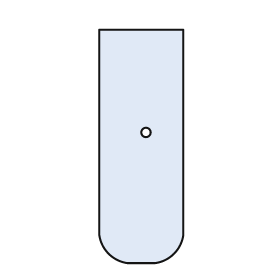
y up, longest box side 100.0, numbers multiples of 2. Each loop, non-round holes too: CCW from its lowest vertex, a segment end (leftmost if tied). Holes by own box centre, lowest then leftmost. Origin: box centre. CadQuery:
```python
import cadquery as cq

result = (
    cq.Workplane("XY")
    .moveTo(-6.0, -50.0)
    .lineTo(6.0, -50.0)
    .threePointArc((14.0, -46.0), (18.0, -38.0))
    .lineTo(18.0, 50.0)
    .lineTo(-18.0, 50.0)
    .lineTo(-18.0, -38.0)
    .threePointArc((-14.0, -46.0), (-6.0, -50.0))
    .close()
    .moveTo(2.0, 6.0)
    .circle(2.0)
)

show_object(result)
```